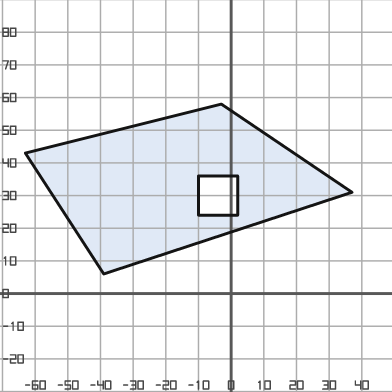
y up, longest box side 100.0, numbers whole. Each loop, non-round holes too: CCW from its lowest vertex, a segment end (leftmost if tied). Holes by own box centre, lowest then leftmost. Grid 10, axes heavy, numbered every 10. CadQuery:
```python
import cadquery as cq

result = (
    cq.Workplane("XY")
    .moveTo(-39.0, 6.0)
    .lineTo(37.0, 31.0)
    .lineTo(-3.0, 58.0)
    .lineTo(-63.0, 43.0)
    .close()
    .moveTo(-10.0, 24.0)
    .lineTo(2.0, 24.0)
    .lineTo(2.0, 36.0)
    .lineTo(-10.0, 36.0)
    .close()
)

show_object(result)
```